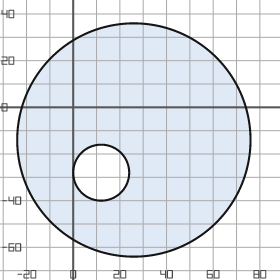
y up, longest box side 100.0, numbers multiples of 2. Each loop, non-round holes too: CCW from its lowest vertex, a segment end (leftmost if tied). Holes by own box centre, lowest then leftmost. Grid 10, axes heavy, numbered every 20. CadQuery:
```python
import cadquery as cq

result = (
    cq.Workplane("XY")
    .moveTo(26.0, -14.0)
    .circle(50.0)
    .moveTo(12.0, -28.0)
    .circle(12.0)
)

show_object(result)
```